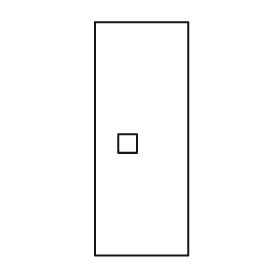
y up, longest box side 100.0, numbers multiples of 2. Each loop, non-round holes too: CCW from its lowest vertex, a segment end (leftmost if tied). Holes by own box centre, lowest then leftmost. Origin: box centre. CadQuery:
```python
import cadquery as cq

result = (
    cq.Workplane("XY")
    .moveTo(-20.0, -50.0)
    .lineTo(20.0, -50.0)
    .lineTo(20.0, 50.0)
    .lineTo(-20.0, 50.0)
    .close()
    .moveTo(-10.0, -6.0)
    .lineTo(-2.0, -6.0)
    .lineTo(-2.0, 2.0)
    .lineTo(-10.0, 2.0)
    .close()
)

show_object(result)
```